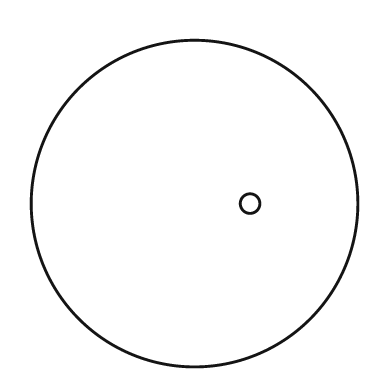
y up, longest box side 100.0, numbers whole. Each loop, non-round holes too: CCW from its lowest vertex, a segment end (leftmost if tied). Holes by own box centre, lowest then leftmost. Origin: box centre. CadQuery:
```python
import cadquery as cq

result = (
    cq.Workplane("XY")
    .moveTo(0.0, 0.0)
    .circle(50.0)
    .moveTo(17.0, 0.0)
    .circle(3.0)
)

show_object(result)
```